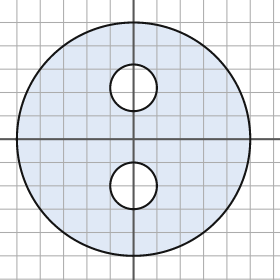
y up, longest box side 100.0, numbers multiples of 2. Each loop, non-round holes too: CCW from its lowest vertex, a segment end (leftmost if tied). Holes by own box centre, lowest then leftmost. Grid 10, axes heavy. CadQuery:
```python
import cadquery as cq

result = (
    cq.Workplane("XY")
    .moveTo(0.0, 0.0)
    .circle(50.0)
    .moveTo(0.0, -20.0)
    .circle(10.0)
    .moveTo(0.0, 22.0)
    .circle(10.0)
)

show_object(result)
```